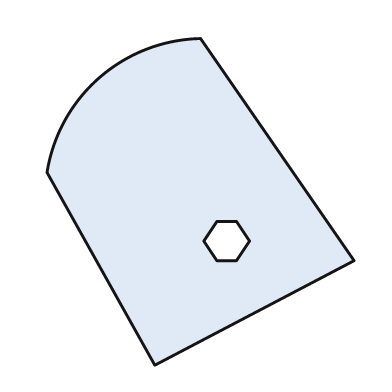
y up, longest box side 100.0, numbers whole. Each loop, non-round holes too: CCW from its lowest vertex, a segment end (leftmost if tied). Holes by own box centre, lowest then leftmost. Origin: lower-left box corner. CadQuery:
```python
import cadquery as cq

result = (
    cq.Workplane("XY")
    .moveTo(33.0, 0.0)
    .lineTo(94.0, 32.0)
    .lineTo(47.0, 100.0)
    .threePointArc((16.0, 88.0), (0.0, 59.0))
    .close()
    .moveTo(52.0, 32.0)
    .lineTo(58.0, 32.0)
    .lineTo(62.0, 38.0)
    .lineTo(58.0, 44.0)
    .lineTo(52.0, 44.0)
    .lineTo(48.0, 38.0)
    .close()
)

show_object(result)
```